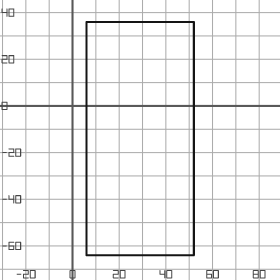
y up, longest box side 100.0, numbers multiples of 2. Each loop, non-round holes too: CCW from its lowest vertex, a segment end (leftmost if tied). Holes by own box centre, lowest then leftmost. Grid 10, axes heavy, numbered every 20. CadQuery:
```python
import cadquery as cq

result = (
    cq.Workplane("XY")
    .moveTo(6.0, -64.0)
    .lineTo(52.0, -64.0)
    .lineTo(52.0, 36.0)
    .lineTo(6.0, 36.0)
    .close()
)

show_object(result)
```